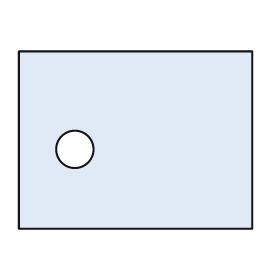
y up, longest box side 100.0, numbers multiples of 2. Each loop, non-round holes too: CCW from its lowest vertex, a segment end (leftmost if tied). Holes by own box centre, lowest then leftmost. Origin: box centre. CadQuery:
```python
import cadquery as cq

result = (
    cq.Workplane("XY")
    .moveTo(-50.0, -38.0)
    .lineTo(50.0, -38.0)
    .lineTo(50.0, 38.0)
    .lineTo(-50.0, 38.0)
    .close()
    .moveTo(-26.0, -4.0)
    .circle(8.0)
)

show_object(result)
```